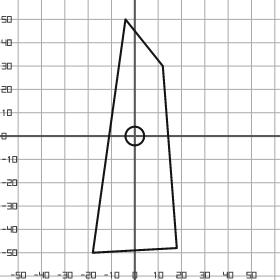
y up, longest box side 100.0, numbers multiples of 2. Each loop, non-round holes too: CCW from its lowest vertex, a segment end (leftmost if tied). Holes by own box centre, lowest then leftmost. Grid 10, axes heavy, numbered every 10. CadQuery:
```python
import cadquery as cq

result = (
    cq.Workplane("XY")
    .moveTo(-18.0, -50.0)
    .lineTo(18.0, -48.0)
    .lineTo(12.0, 30.0)
    .lineTo(-4.0, 50.0)
    .close()
    .moveTo(0.0, 0.0)
    .circle(4.0)
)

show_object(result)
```